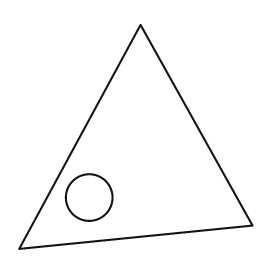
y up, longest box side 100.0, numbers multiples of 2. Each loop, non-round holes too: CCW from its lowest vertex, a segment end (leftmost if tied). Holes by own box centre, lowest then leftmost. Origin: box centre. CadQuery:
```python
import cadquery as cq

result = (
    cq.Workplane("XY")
    .moveTo(-50.0, -48.0)
    .lineTo(50.0, -38.0)
    .lineTo(2.0, 48.0)
    .close()
    .moveTo(-20.0, -26.0)
    .circle(10.0)
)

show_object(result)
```